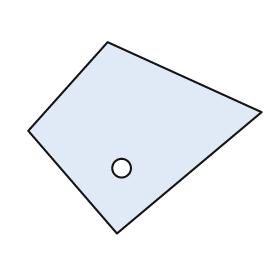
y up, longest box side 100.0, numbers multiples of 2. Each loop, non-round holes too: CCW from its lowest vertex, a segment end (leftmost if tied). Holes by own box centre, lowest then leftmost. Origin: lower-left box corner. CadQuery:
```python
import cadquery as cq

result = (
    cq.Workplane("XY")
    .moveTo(38.0, 0.0)
    .lineTo(100.0, 52.0)
    .lineTo(34.0, 82.0)
    .lineTo(0.0, 44.0)
    .close()
    .moveTo(40.0, 28.0)
    .circle(4.0)
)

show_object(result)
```